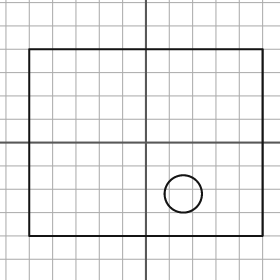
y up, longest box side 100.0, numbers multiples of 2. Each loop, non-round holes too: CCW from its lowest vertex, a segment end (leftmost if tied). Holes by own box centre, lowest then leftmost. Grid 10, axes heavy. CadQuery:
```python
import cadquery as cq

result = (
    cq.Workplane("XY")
    .moveTo(-50.0, -40.0)
    .lineTo(50.0, -40.0)
    .lineTo(50.0, 40.0)
    .lineTo(-50.0, 40.0)
    .close()
    .moveTo(16.0, -22.0)
    .circle(8.0)
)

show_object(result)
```